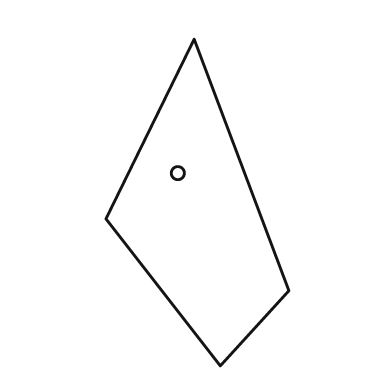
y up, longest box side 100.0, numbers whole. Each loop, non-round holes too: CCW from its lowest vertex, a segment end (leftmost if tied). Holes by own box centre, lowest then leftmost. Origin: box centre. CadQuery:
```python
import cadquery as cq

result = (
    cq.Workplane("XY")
    .moveTo(7.0, -50.0)
    .lineTo(28.0, -27.0)
    .lineTo(-1.0, 50.0)
    .lineTo(-28.0, -5.0)
    .close()
    .moveTo(-6.0, 9.0)
    .circle(2.0)
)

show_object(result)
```